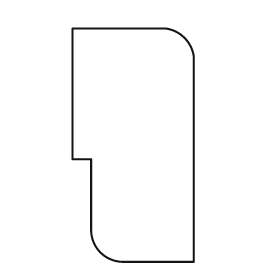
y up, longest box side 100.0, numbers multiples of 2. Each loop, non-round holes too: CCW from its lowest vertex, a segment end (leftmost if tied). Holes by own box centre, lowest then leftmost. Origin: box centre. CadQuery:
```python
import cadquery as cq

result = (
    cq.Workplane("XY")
    .moveTo(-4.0, -50.0)
    .lineTo(26.0, -50.0)
    .lineTo(26.0, 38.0)
    .threePointArc((22.0, 46.0), (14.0, 50.0))
    .lineTo(-26.0, 50.0)
    .lineTo(-26.0, -6.0)
    .lineTo(-18.0, -6.0)
    .lineTo(-18.0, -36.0)
    .threePointArc((-14.0, -46.0), (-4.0, -50.0))
    .close()
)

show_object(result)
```